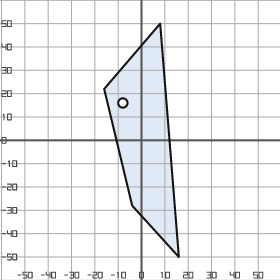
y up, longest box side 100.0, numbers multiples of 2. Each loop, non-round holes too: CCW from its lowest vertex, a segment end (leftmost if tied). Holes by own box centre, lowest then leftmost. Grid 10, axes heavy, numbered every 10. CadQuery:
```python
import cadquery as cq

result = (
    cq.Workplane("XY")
    .moveTo(16.0, -50.0)
    .lineTo(8.0, 50.0)
    .lineTo(-16.0, 22.0)
    .lineTo(-4.0, -28.0)
    .close()
    .moveTo(-8.0, 16.0)
    .circle(2.0)
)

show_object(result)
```